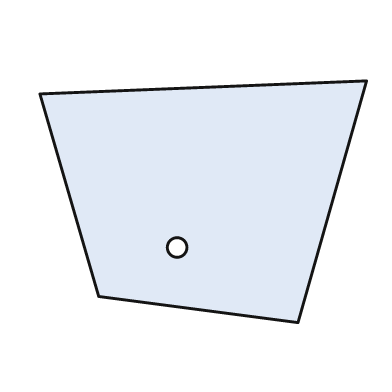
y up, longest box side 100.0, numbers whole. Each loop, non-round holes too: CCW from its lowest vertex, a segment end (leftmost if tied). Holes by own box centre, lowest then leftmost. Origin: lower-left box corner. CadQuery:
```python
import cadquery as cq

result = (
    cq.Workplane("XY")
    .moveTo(79.0, 0.0)
    .lineTo(100.0, 74.0)
    .lineTo(0.0, 70.0)
    .lineTo(18.0, 8.0)
    .close()
    .moveTo(42.0, 23.0)
    .circle(3.0)
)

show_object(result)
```